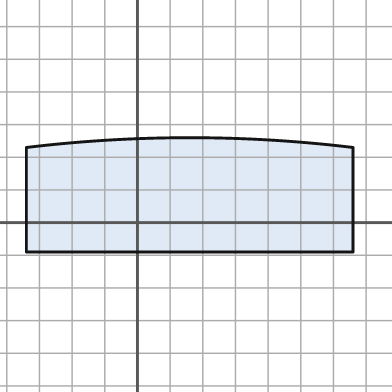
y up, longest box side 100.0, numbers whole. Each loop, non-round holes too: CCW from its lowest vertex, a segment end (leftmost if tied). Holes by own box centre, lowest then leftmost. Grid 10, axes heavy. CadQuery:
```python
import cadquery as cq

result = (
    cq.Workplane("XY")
    .moveTo(-34.0, -9.0)
    .lineTo(66.0, -9.0)
    .lineTo(66.0, 23.0)
    .threePointArc((16.0, 26.0), (-34.0, 23.0))
    .close()
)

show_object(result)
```